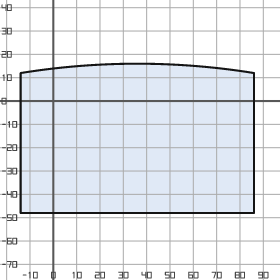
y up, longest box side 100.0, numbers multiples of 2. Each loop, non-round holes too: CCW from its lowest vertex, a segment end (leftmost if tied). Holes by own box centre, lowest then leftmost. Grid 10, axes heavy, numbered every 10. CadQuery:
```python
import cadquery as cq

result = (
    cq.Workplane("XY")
    .moveTo(-14.0, -48.0)
    .lineTo(86.0, -48.0)
    .lineTo(86.0, 12.0)
    .threePointArc((36.0, 16.0), (-14.0, 12.0))
    .close()
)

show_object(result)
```